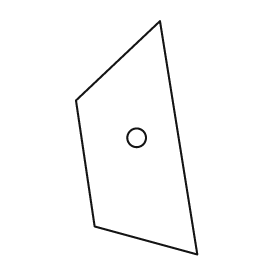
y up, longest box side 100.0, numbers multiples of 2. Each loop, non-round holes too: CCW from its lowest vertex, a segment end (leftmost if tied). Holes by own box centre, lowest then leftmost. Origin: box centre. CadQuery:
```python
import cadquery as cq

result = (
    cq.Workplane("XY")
    .moveTo(26.0, -50.0)
    .lineTo(10.0, 50.0)
    .lineTo(-26.0, 16.0)
    .lineTo(-18.0, -38.0)
    .close()
    .moveTo(0.0, 0.0)
    .circle(4.0)
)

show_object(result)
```